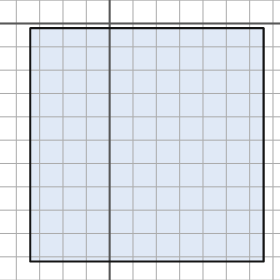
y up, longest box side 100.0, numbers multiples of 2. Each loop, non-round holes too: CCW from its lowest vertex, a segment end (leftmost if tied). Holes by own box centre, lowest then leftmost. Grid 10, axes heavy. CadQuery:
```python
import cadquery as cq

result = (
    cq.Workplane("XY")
    .moveTo(-34.0, -102.0)
    .lineTo(66.0, -102.0)
    .lineTo(66.0, -2.0)
    .lineTo(-34.0, -2.0)
    .close()
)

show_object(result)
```